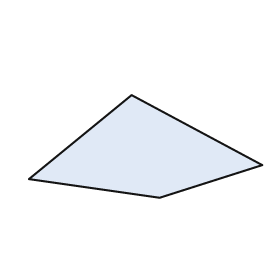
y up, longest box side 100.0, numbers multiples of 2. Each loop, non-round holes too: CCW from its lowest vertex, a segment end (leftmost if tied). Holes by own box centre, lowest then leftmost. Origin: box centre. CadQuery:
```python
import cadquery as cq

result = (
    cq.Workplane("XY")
    .moveTo(6.0, -22.0)
    .lineTo(50.0, -8.0)
    .lineTo(-6.0, 22.0)
    .lineTo(-50.0, -14.0)
    .close()
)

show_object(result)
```